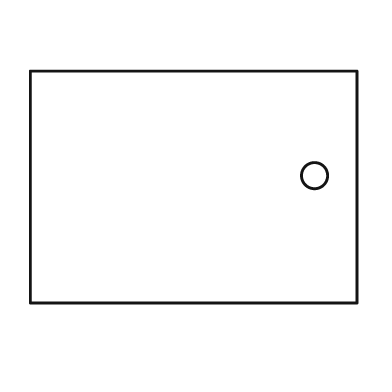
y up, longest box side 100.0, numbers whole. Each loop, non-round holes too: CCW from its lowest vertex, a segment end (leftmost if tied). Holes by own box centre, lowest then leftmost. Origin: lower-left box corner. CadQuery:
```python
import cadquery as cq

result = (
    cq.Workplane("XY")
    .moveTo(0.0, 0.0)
    .lineTo(100.0, 0.0)
    .lineTo(100.0, 71.0)
    .lineTo(0.0, 71.0)
    .close()
    .moveTo(87.0, 39.0)
    .circle(4.0)
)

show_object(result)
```